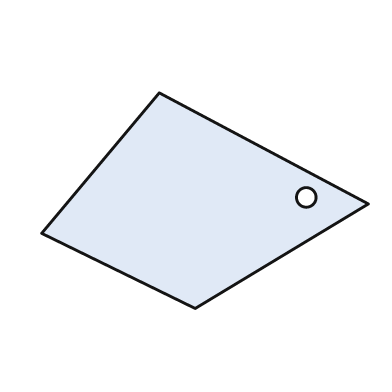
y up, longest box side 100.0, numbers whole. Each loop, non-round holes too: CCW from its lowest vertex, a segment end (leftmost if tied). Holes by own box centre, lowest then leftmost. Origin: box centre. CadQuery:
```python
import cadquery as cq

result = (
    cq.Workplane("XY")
    .moveTo(-3.0, -33.0)
    .lineTo(50.0, -1.0)
    .lineTo(-14.0, 33.0)
    .lineTo(-50.0, -10.0)
    .close()
    .moveTo(31.0, 1.0)
    .circle(3.0)
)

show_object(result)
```